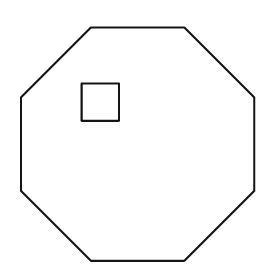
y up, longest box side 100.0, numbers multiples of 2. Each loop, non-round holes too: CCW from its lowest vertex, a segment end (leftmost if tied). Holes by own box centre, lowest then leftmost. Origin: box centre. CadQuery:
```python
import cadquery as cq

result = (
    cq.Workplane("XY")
    .moveTo(-20.0, -50.0)
    .lineTo(20.0, -50.0)
    .lineTo(50.0, -20.0)
    .lineTo(50.0, 20.0)
    .lineTo(20.0, 50.0)
    .lineTo(-20.0, 50.0)
    .lineTo(-50.0, 20.0)
    .lineTo(-50.0, -20.0)
    .close()
    .moveTo(-24.0, 10.0)
    .lineTo(-8.0, 10.0)
    .lineTo(-8.0, 26.0)
    .lineTo(-24.0, 26.0)
    .close()
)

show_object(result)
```